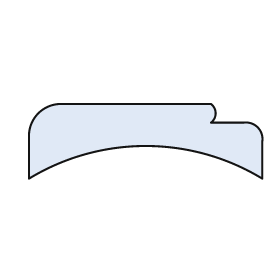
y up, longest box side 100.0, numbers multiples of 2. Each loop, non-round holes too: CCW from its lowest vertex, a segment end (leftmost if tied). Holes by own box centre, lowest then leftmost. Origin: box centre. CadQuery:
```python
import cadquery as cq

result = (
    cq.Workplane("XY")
    .moveTo(-50.0, -16.0)
    .threePointArc((0.0, -2.0), (50.0, -16.0))
    .lineTo(50.0, 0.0)
    .threePointArc((48.0, 6.0), (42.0, 8.0))
    .lineTo(28.0, 8.0)
    .threePointArc((30.0, 12.0), (28.0, 16.0))
    .lineTo(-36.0, 16.0)
    .threePointArc((-46.0, 12.0), (-50.0, 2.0))
    .close()
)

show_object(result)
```